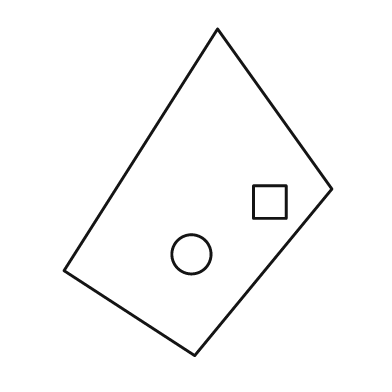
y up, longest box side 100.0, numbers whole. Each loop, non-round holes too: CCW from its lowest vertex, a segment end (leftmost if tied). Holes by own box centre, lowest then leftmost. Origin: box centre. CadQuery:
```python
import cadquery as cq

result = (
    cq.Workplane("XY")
    .moveTo(-1.0, -50.0)
    .lineTo(41.0, 1.0)
    .lineTo(6.0, 50.0)
    .lineTo(-41.0, -24.0)
    .close()
    .moveTo(-2.0, -19.0)
    .circle(6.0)
    .moveTo(17.0, -8.0)
    .lineTo(27.0, -8.0)
    .lineTo(27.0, 2.0)
    .lineTo(17.0, 2.0)
    .close()
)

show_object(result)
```